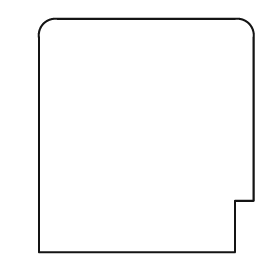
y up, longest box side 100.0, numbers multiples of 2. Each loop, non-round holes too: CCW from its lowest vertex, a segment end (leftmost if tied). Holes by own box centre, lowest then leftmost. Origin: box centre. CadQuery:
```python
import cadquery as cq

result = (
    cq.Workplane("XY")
    .moveTo(-46.0, -50.0)
    .lineTo(38.0, -50.0)
    .lineTo(38.0, -28.0)
    .lineTo(46.0, -28.0)
    .lineTo(46.0, 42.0)
    .threePointArc((44.0, 48.0), (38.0, 50.0))
    .lineTo(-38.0, 50.0)
    .threePointArc((-44.0, 48.0), (-46.0, 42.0))
    .close()
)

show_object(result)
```